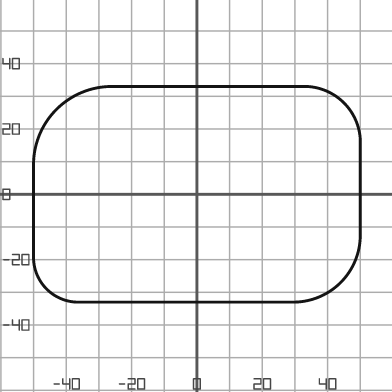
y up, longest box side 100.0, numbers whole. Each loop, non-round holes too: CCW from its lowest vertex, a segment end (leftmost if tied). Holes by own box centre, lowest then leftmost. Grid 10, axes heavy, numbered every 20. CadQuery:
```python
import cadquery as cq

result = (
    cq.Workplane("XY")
    .moveTo(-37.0, -33.0)
    .lineTo(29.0, -33.0)
    .threePointArc((44.0, -27.0), (50.0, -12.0))
    .lineTo(50.0, 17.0)
    .threePointArc((45.0, 28.0), (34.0, 33.0))
    .lineTo(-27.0, 33.0)
    .threePointArc((-43.0, 26.0), (-50.0, 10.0))
    .lineTo(-50.0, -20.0)
    .threePointArc((-46.0, -29.0), (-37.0, -33.0))
    .close()
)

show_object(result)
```